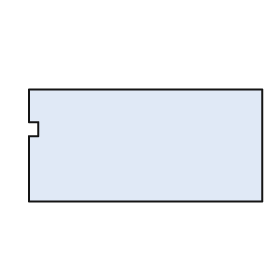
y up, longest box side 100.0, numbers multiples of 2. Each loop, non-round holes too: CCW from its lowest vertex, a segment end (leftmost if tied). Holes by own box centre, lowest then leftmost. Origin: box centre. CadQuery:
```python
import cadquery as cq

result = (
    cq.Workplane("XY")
    .moveTo(-50.0, -24.0)
    .lineTo(50.0, -24.0)
    .lineTo(50.0, 24.0)
    .lineTo(-50.0, 24.0)
    .lineTo(-50.0, 10.0)
    .lineTo(-46.0, 10.0)
    .lineTo(-46.0, 4.0)
    .lineTo(-50.0, 4.0)
    .close()
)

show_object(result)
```